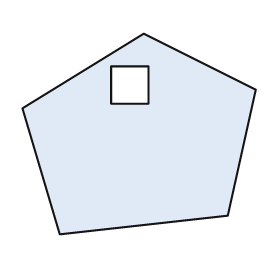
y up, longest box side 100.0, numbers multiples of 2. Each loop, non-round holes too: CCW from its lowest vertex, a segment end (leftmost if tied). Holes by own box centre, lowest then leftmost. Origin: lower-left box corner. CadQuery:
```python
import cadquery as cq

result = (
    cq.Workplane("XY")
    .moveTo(16.0, 0.0)
    .lineTo(88.0, 8.0)
    .lineTo(100.0, 62.0)
    .lineTo(52.0, 86.0)
    .lineTo(0.0, 54.0)
    .close()
    .moveTo(38.0, 56.0)
    .lineTo(54.0, 56.0)
    .lineTo(54.0, 72.0)
    .lineTo(38.0, 72.0)
    .close()
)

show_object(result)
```